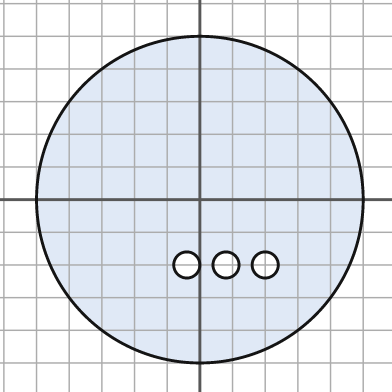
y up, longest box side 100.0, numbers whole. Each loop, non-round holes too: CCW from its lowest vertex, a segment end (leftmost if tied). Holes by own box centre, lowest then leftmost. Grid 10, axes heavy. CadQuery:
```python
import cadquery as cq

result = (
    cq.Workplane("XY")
    .moveTo(0.0, 0.0)
    .circle(50.0)
    .moveTo(-4.0, -20.0)
    .circle(4.0)
    .moveTo(8.0, -20.0)
    .circle(4.0)
    .moveTo(20.0, -20.0)
    .circle(4.0)
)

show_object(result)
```